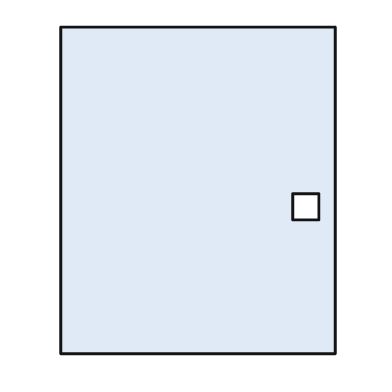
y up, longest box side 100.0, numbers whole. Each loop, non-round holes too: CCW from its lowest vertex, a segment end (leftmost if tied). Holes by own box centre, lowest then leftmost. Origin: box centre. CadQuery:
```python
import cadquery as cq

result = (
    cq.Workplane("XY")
    .moveTo(-42.0, -50.0)
    .lineTo(42.0, -50.0)
    .lineTo(42.0, 50.0)
    .lineTo(-42.0, 50.0)
    .close()
    .moveTo(29.0, -9.0)
    .lineTo(37.0, -9.0)
    .lineTo(37.0, -1.0)
    .lineTo(29.0, -1.0)
    .close()
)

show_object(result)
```